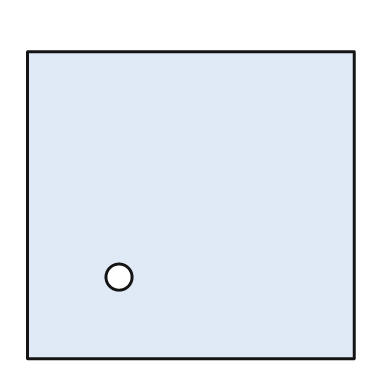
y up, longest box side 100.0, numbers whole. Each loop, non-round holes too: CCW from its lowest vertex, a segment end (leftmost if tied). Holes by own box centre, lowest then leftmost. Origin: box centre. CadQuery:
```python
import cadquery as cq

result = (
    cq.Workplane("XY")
    .moveTo(-50.0, -47.0)
    .lineTo(50.0, -47.0)
    .lineTo(50.0, 47.0)
    .lineTo(-50.0, 47.0)
    .close()
    .moveTo(-22.0, -22.0)
    .circle(4.0)
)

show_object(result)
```